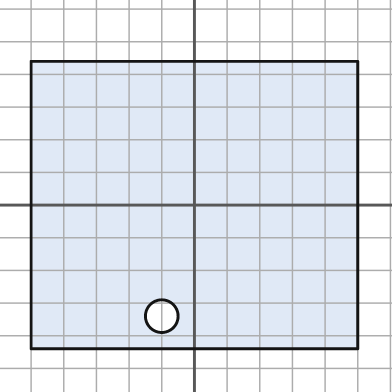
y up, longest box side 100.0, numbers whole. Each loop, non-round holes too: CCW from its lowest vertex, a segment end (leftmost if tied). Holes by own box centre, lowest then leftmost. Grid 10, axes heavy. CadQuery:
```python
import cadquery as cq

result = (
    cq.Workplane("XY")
    .moveTo(-50.0, -44.0)
    .lineTo(50.0, -44.0)
    .lineTo(50.0, 44.0)
    .lineTo(-50.0, 44.0)
    .close()
    .moveTo(-10.0, -34.0)
    .circle(5.0)
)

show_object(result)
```